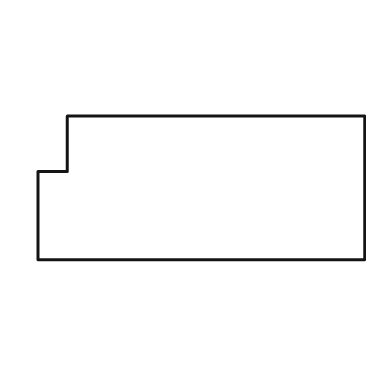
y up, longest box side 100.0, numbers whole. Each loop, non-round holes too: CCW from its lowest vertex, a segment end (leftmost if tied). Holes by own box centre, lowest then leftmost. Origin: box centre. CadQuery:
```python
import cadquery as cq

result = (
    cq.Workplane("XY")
    .moveTo(-50.0, -22.0)
    .lineTo(50.0, -22.0)
    .lineTo(50.0, 22.0)
    .lineTo(-41.0, 22.0)
    .lineTo(-41.0, 5.0)
    .lineTo(-50.0, 5.0)
    .close()
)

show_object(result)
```